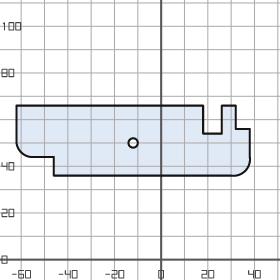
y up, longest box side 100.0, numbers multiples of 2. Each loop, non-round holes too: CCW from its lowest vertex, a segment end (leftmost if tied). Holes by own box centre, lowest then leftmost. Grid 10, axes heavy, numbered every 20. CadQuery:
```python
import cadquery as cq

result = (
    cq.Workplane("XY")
    .moveTo(-46.0, 36.0)
    .lineTo(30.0, 36.0)
    .threePointArc((36.0, 38.0), (38.0, 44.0))
    .lineTo(38.0, 56.0)
    .lineTo(32.0, 56.0)
    .lineTo(32.0, 66.0)
    .lineTo(26.0, 66.0)
    .lineTo(26.0, 54.0)
    .lineTo(18.0, 54.0)
    .lineTo(18.0, 66.0)
    .lineTo(-62.0, 66.0)
    .lineTo(-62.0, 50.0)
    .threePointArc((-60.0, 46.0), (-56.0, 44.0))
    .lineTo(-46.0, 44.0)
    .close()
    .moveTo(-12.0, 50.0)
    .circle(2.0)
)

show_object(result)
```